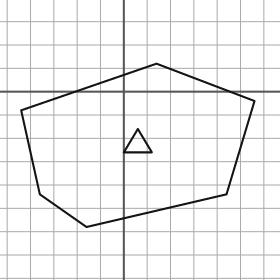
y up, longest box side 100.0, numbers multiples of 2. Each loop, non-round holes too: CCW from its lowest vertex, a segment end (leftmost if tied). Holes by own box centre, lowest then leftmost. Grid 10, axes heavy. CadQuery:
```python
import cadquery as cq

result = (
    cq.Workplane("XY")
    .moveTo(-16.0, -58.0)
    .lineTo(44.0, -44.0)
    .lineTo(56.0, -4.0)
    .lineTo(14.0, 12.0)
    .lineTo(-44.0, -8.0)
    .lineTo(-36.0, -44.0)
    .close()
    .moveTo(0.0, -26.0)
    .lineTo(12.0, -26.0)
    .lineTo(6.0, -16.0)
    .close()
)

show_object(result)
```